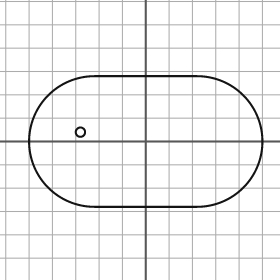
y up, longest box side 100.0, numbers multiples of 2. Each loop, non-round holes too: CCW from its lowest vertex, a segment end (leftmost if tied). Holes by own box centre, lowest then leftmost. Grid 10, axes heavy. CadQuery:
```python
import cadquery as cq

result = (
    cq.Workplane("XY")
    .moveTo(-22.0, -28.0)
    .lineTo(22.0, -28.0)
    .threePointArc((50.0, 0.0), (22.0, 28.0))
    .lineTo(-22.0, 28.0)
    .threePointArc((-50.0, 0.0), (-22.0, -28.0))
    .close()
    .moveTo(-28.0, 4.0)
    .circle(2.0)
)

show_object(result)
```